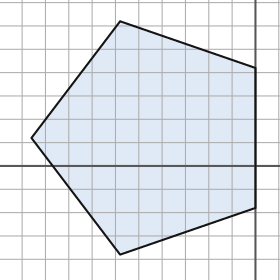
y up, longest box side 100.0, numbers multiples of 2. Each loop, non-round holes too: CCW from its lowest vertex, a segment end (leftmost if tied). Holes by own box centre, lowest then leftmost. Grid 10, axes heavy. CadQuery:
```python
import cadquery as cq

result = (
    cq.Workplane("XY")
    .moveTo(-58.0, -38.0)
    .lineTo(0.0, -18.0)
    .lineTo(0.0, 42.0)
    .lineTo(-58.0, 62.0)
    .lineTo(-96.0, 12.0)
    .close()
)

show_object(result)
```